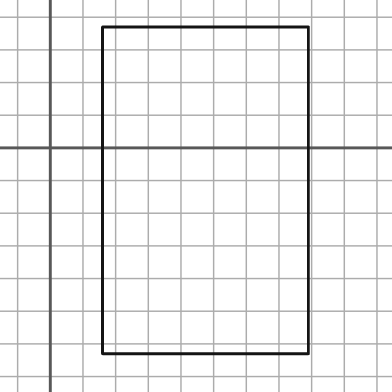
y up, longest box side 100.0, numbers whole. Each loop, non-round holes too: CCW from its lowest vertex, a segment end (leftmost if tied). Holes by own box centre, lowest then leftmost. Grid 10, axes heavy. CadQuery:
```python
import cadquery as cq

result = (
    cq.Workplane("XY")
    .moveTo(16.0, -63.0)
    .lineTo(79.0, -63.0)
    .lineTo(79.0, 37.0)
    .lineTo(16.0, 37.0)
    .close()
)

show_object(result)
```